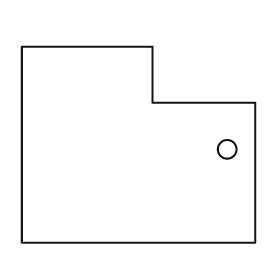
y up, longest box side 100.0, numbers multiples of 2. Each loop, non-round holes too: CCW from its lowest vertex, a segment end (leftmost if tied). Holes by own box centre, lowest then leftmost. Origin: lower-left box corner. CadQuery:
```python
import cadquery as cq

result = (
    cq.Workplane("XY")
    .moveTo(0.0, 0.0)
    .lineTo(100.0, 0.0)
    .lineTo(100.0, 60.0)
    .lineTo(56.0, 60.0)
    .lineTo(56.0, 84.0)
    .lineTo(0.0, 84.0)
    .close()
    .moveTo(88.0, 40.0)
    .circle(4.0)
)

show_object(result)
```